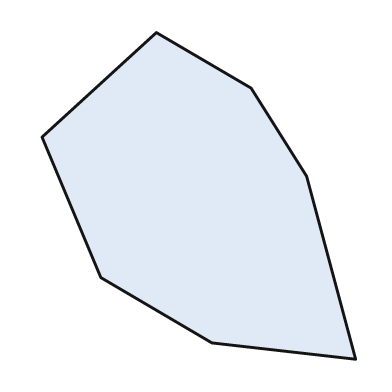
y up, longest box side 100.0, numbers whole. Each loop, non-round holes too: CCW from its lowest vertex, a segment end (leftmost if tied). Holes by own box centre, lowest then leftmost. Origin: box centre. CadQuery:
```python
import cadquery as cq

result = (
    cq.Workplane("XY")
    .moveTo(48.0, -50.0)
    .lineTo(33.0, 6.0)
    .lineTo(16.0, 33.0)
    .lineTo(-13.0, 50.0)
    .lineTo(-48.0, 18.0)
    .lineTo(-30.0, -25.0)
    .lineTo(4.0, -45.0)
    .close()
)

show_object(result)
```